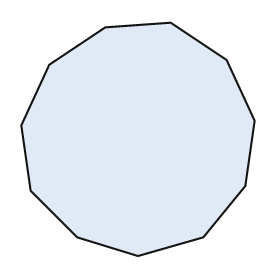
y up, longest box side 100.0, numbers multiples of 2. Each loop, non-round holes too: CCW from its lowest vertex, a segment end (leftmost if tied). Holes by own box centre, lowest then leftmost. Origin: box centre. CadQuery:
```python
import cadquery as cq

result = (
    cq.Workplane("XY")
    .moveTo(0.0, -50.0)
    .lineTo(28.0, -42.0)
    .lineTo(46.0, -20.0)
    .lineTo(50.0, 8.0)
    .lineTo(38.0, 34.0)
    .lineTo(14.0, 50.0)
    .lineTo(-14.0, 48.0)
    .lineTo(-38.0, 32.0)
    .lineTo(-50.0, 6.0)
    .lineTo(-46.0, -22.0)
    .lineTo(-26.0, -42.0)
    .close()
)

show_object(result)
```